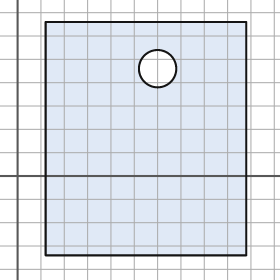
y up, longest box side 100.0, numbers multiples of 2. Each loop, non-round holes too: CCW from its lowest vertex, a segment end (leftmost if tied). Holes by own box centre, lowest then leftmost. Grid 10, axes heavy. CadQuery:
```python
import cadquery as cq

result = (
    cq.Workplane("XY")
    .moveTo(12.0, -34.0)
    .lineTo(98.0, -34.0)
    .lineTo(98.0, 66.0)
    .lineTo(12.0, 66.0)
    .close()
    .moveTo(60.0, 46.0)
    .circle(8.0)
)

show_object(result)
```